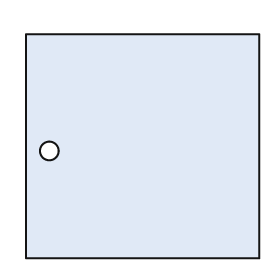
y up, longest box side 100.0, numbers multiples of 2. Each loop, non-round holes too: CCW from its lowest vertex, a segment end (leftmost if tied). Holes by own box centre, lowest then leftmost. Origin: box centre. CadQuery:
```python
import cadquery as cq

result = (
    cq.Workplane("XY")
    .moveTo(-50.0, -48.0)
    .lineTo(50.0, -48.0)
    .lineTo(50.0, 48.0)
    .lineTo(-50.0, 48.0)
    .close()
    .moveTo(-40.0, -2.0)
    .circle(4.0)
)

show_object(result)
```